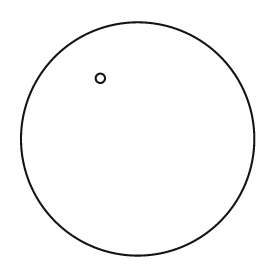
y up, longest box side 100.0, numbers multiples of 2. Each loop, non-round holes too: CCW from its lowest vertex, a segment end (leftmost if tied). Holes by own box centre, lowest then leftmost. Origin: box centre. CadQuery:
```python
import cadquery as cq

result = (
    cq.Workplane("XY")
    .moveTo(0.0, 0.0)
    .circle(50.0)
    .moveTo(-16.0, 26.0)
    .circle(2.0)
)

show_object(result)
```